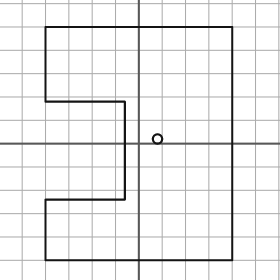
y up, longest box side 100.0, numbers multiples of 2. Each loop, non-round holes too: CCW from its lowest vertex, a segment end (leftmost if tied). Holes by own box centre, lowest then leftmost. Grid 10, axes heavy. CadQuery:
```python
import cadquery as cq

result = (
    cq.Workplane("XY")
    .moveTo(-40.0, -50.0)
    .lineTo(40.0, -50.0)
    .lineTo(40.0, 50.0)
    .lineTo(-40.0, 50.0)
    .lineTo(-40.0, 18.0)
    .lineTo(-6.0, 18.0)
    .lineTo(-6.0, -24.0)
    .lineTo(-40.0, -24.0)
    .close()
    .moveTo(8.0, 2.0)
    .circle(2.0)
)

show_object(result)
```